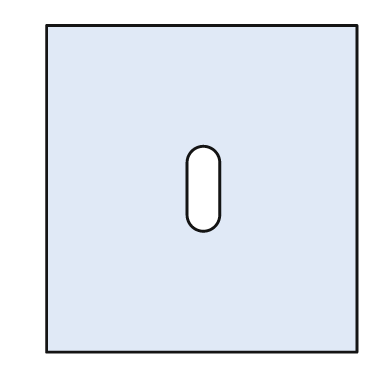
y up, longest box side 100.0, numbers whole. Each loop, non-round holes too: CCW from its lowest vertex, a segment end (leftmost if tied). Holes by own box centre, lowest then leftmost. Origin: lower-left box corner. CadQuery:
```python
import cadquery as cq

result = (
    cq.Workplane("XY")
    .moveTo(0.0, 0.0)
    .lineTo(95.0, 0.0)
    .lineTo(95.0, 100.0)
    .lineTo(0.0, 100.0)
    .close()
    .moveTo(43.0, 42.0)
    .threePointArc((48.0, 37.0), (53.0, 42.0))
    .lineTo(53.0, 58.0)
    .threePointArc((48.0, 63.0), (43.0, 58.0))
    .close()
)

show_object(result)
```